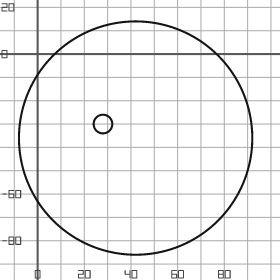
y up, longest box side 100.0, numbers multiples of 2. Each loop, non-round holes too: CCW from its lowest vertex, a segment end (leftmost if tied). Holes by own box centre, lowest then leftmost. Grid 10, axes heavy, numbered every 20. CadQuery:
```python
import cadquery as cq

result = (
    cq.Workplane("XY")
    .moveTo(42.0, -36.0)
    .circle(50.0)
    .moveTo(28.0, -30.0)
    .circle(4.0)
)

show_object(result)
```